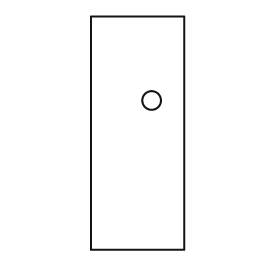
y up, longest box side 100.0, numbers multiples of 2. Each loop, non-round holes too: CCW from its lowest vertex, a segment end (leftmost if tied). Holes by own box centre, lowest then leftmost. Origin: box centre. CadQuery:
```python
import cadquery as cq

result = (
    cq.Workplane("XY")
    .moveTo(-20.0, -50.0)
    .lineTo(20.0, -50.0)
    .lineTo(20.0, 50.0)
    .lineTo(-20.0, 50.0)
    .close()
    .moveTo(6.0, 14.0)
    .circle(4.0)
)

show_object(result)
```